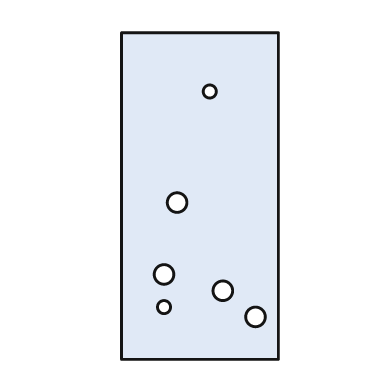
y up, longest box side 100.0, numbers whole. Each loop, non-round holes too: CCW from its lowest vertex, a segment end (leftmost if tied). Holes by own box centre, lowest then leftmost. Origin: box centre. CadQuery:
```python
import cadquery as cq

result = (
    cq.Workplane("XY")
    .moveTo(-24.0, -50.0)
    .lineTo(24.0, -50.0)
    .lineTo(24.0, 50.0)
    .lineTo(-24.0, 50.0)
    .close()
    .moveTo(17.0, -37.0)
    .circle(3.0)
    .moveTo(-11.0, -34.0)
    .circle(2.0)
    .moveTo(7.0, -29.0)
    .circle(3.0)
    .moveTo(-11.0, -24.0)
    .circle(3.0)
    .moveTo(-7.0, -2.0)
    .circle(3.0)
    .moveTo(3.0, 32.0)
    .circle(2.0)
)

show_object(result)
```